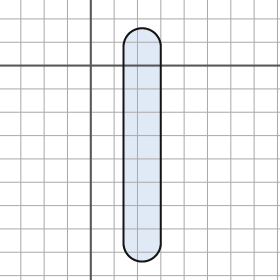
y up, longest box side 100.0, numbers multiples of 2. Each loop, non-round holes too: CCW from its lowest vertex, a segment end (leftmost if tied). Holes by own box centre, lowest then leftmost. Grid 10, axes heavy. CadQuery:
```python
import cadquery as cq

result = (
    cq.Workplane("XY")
    .moveTo(14.0, -76.0)
    .threePointArc((22.0, -84.0), (30.0, -76.0))
    .lineTo(30.0, 8.0)
    .threePointArc((22.0, 16.0), (14.0, 8.0))
    .close()
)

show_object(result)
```